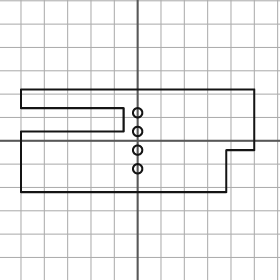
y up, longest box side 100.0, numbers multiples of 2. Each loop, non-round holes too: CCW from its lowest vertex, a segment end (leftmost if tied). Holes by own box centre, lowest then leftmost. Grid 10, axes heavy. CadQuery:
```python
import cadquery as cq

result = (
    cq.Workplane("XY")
    .moveTo(-50.0, -22.0)
    .lineTo(38.0, -22.0)
    .lineTo(38.0, -4.0)
    .lineTo(50.0, -4.0)
    .lineTo(50.0, 22.0)
    .lineTo(-50.0, 22.0)
    .lineTo(-50.0, 14.0)
    .lineTo(-6.0, 14.0)
    .lineTo(-6.0, 4.0)
    .lineTo(-50.0, 4.0)
    .close()
    .moveTo(0.0, -12.0)
    .circle(2.0)
    .moveTo(0.0, -4.0)
    .circle(2.0)
    .moveTo(0.0, 4.0)
    .circle(2.0)
    .moveTo(0.0, 12.0)
    .circle(2.0)
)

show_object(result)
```